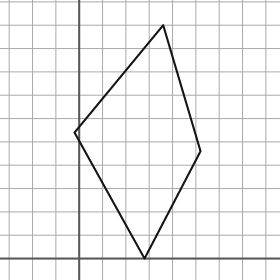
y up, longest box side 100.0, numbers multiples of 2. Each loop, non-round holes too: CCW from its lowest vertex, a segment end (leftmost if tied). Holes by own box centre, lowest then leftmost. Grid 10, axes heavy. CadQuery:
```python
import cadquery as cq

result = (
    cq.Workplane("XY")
    .moveTo(28.0, 0.0)
    .lineTo(52.0, 46.0)
    .lineTo(36.0, 100.0)
    .lineTo(-2.0, 54.0)
    .close()
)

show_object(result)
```